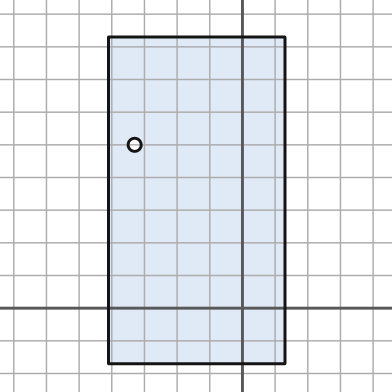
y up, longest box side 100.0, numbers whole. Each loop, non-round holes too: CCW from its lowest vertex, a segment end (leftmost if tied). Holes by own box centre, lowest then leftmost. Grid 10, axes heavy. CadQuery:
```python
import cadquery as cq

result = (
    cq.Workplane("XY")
    .moveTo(-41.0, -17.0)
    .lineTo(13.0, -17.0)
    .lineTo(13.0, 83.0)
    .lineTo(-41.0, 83.0)
    .close()
    .moveTo(-33.0, 50.0)
    .circle(2.0)
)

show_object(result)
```